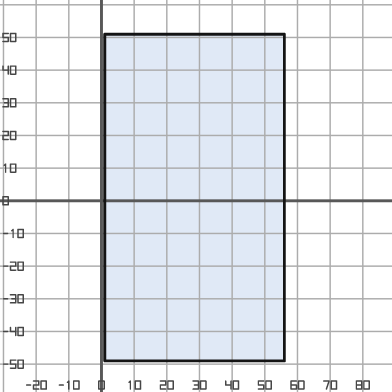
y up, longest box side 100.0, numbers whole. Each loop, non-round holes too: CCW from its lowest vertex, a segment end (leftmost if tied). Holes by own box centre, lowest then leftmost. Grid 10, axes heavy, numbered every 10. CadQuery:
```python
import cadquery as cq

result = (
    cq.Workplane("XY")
    .moveTo(1.0, -49.0)
    .lineTo(56.0, -49.0)
    .lineTo(56.0, 51.0)
    .lineTo(1.0, 51.0)
    .close()
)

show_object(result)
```